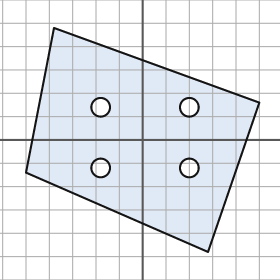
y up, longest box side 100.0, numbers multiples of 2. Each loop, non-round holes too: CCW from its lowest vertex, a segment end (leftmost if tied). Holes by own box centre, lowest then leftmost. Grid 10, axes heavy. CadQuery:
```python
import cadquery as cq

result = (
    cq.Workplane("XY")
    .moveTo(28.0, -48.0)
    .lineTo(50.0, 16.0)
    .lineTo(-38.0, 48.0)
    .lineTo(-50.0, -14.0)
    .close()
    .moveTo(-18.0, -12.0)
    .circle(4.0)
    .moveTo(20.0, -12.0)
    .circle(4.0)
    .moveTo(-18.0, 14.0)
    .circle(4.0)
    .moveTo(20.0, 14.0)
    .circle(4.0)
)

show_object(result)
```